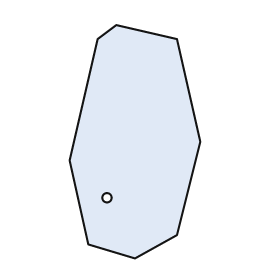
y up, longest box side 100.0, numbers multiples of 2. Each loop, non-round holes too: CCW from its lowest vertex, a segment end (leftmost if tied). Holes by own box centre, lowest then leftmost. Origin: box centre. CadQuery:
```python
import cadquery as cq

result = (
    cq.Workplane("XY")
    .moveTo(0.0, -50.0)
    .lineTo(18.0, -40.0)
    .lineTo(28.0, 0.0)
    .lineTo(18.0, 44.0)
    .lineTo(-8.0, 50.0)
    .lineTo(-16.0, 44.0)
    .lineTo(-28.0, -8.0)
    .lineTo(-20.0, -44.0)
    .close()
    .moveTo(-12.0, -24.0)
    .circle(2.0)
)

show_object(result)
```